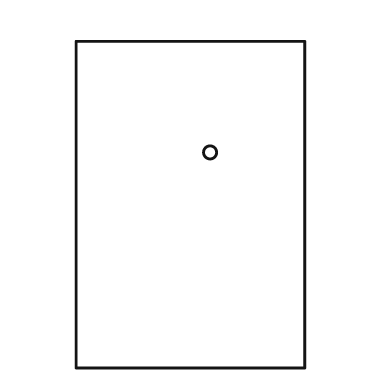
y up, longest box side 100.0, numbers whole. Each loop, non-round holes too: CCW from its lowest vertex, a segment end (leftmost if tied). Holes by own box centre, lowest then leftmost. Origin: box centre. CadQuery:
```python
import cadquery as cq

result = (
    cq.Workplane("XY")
    .moveTo(-35.0, -50.0)
    .lineTo(35.0, -50.0)
    .lineTo(35.0, 50.0)
    .lineTo(-35.0, 50.0)
    .close()
    .moveTo(6.0, 16.0)
    .circle(2.0)
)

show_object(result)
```